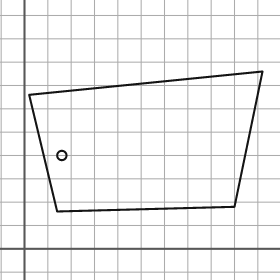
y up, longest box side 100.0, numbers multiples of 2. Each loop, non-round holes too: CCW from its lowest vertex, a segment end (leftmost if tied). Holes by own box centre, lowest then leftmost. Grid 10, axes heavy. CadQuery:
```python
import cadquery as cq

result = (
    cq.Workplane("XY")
    .moveTo(14.0, 16.0)
    .lineTo(90.0, 18.0)
    .lineTo(102.0, 76.0)
    .lineTo(2.0, 66.0)
    .close()
    .moveTo(16.0, 40.0)
    .circle(2.0)
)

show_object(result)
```